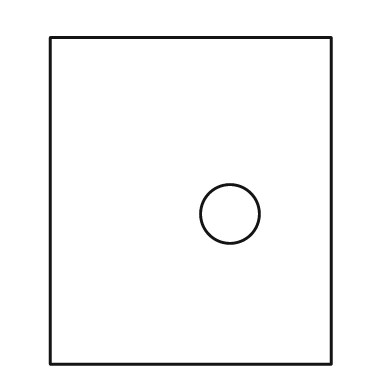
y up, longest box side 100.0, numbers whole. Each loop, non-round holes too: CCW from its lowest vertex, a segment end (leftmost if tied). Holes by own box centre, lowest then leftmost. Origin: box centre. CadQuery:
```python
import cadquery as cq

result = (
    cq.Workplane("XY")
    .moveTo(-43.0, -50.0)
    .lineTo(43.0, -50.0)
    .lineTo(43.0, 50.0)
    .lineTo(-43.0, 50.0)
    .close()
    .moveTo(12.0, -4.0)
    .circle(9.0)
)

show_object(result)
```